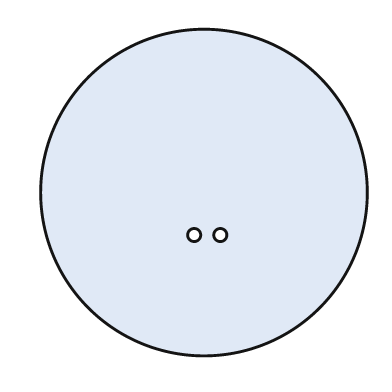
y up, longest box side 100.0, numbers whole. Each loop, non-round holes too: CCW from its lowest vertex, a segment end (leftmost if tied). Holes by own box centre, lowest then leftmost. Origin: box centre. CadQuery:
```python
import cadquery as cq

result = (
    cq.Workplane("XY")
    .moveTo(0.0, 0.0)
    .circle(50.0)
    .moveTo(-3.0, -13.0)
    .circle(2.0)
    .moveTo(5.0, -13.0)
    .circle(2.0)
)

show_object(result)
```